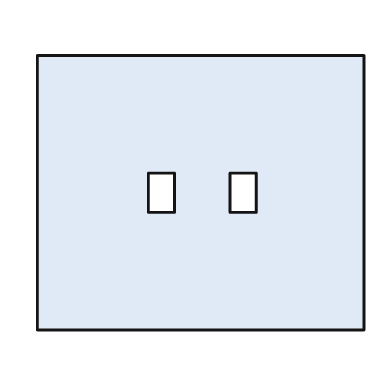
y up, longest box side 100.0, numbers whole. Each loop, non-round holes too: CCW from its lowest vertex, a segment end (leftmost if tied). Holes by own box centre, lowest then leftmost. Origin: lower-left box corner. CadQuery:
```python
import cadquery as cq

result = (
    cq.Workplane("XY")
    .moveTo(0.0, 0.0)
    .lineTo(100.0, 0.0)
    .lineTo(100.0, 84.0)
    .lineTo(0.0, 84.0)
    .close()
    .moveTo(34.0, 36.0)
    .lineTo(42.0, 36.0)
    .lineTo(42.0, 48.0)
    .lineTo(34.0, 48.0)
    .close()
    .moveTo(59.0, 36.0)
    .lineTo(67.0, 36.0)
    .lineTo(67.0, 48.0)
    .lineTo(59.0, 48.0)
    .close()
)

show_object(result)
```